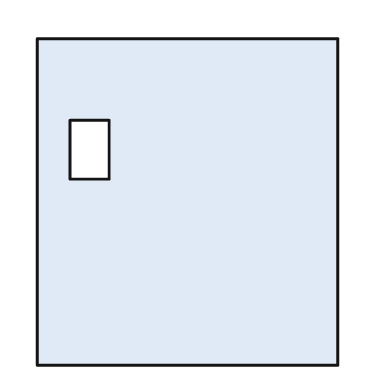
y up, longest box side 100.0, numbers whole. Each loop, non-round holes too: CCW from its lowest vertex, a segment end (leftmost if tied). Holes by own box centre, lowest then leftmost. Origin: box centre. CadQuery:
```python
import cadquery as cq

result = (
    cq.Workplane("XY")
    .moveTo(-46.0, -50.0)
    .lineTo(46.0, -50.0)
    .lineTo(46.0, 50.0)
    .lineTo(-46.0, 50.0)
    .close()
    .moveTo(-36.0, 7.0)
    .lineTo(-24.0, 7.0)
    .lineTo(-24.0, 25.0)
    .lineTo(-36.0, 25.0)
    .close()
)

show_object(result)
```